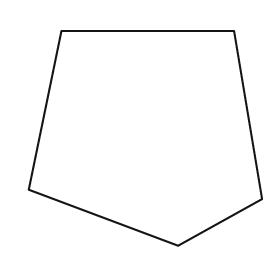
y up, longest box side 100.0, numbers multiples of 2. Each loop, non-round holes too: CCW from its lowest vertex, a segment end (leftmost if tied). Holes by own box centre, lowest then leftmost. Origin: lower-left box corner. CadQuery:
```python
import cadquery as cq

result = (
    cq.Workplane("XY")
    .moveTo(64.0, 0.0)
    .lineTo(100.0, 20.0)
    .lineTo(88.0, 92.0)
    .lineTo(14.0, 92.0)
    .lineTo(0.0, 24.0)
    .close()
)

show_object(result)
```